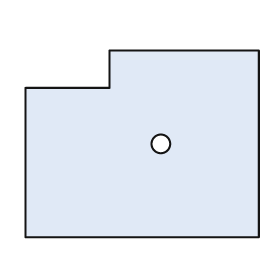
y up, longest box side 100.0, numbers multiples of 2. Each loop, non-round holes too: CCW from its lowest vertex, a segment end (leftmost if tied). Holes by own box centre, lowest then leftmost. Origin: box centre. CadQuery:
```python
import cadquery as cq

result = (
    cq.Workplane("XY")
    .moveTo(-50.0, -40.0)
    .lineTo(50.0, -40.0)
    .lineTo(50.0, 40.0)
    .lineTo(-14.0, 40.0)
    .lineTo(-14.0, 24.0)
    .lineTo(-50.0, 24.0)
    .close()
    .moveTo(8.0, 0.0)
    .circle(4.0)
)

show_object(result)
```